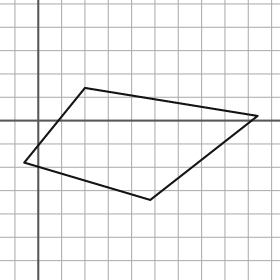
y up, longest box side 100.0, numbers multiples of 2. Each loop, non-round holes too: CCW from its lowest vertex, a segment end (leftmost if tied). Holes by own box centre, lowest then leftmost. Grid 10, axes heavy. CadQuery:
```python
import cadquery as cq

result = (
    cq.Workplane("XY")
    .moveTo(48.0, -34.0)
    .lineTo(94.0, 2.0)
    .lineTo(20.0, 14.0)
    .lineTo(-6.0, -18.0)
    .close()
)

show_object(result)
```